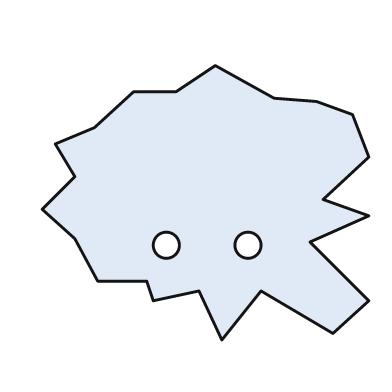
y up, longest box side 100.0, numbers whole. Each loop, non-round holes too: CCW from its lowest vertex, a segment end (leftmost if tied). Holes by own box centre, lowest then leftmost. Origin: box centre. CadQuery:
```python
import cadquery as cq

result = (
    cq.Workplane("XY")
    .moveTo(5.0, -42.0)
    .lineTo(17.0, -27.0)
    .lineTo(39.0, -40.0)
    .lineTo(50.0, -30.0)
    .lineTo(32.0, -12.0)
    .lineTo(50.0, -4.0)
    .lineTo(36.0, 1.0)
    .lineTo(50.0, 14.0)
    .lineTo(45.0, 27.0)
    .lineTo(34.0, 31.0)
    .lineTo(21.0, 32.0)
    .lineTo(3.0, 42.0)
    .lineTo(-9.0, 34.0)
    .lineTo(-22.0, 34.0)
    .lineTo(-34.0, 23.0)
    .lineTo(-46.0, 18.0)
    .lineTo(-40.0, 8.0)
    .lineTo(-50.0, -2.0)
    .lineTo(-40.0, -11.0)
    .lineTo(-33.0, -24.0)
    .lineTo(-18.0, -24.0)
    .lineTo(-16.0, -30.0)
    .lineTo(-2.0, -27.0)
    .close()
    .moveTo(-12.0, -13.0)
    .circle(4.0)
    .moveTo(13.0, -13.0)
    .circle(4.0)
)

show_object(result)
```